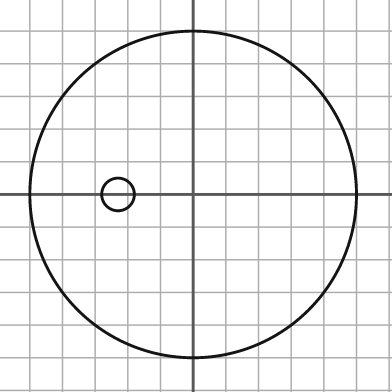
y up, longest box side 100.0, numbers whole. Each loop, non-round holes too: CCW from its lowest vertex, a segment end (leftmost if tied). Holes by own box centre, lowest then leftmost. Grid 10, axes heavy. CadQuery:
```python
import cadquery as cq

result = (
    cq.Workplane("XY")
    .moveTo(0.0, 0.0)
    .circle(50.0)
    .moveTo(-23.0, 0.0)
    .circle(5.0)
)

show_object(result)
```